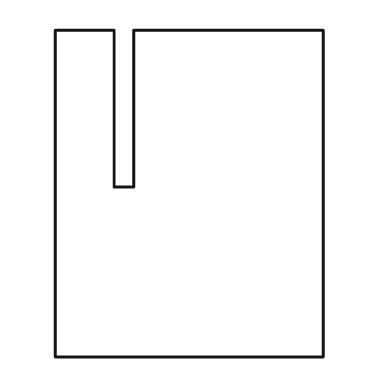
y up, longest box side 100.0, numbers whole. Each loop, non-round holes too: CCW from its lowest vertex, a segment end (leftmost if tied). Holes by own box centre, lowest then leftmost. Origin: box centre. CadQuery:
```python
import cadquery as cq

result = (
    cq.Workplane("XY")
    .moveTo(-41.0, -50.0)
    .lineTo(41.0, -50.0)
    .lineTo(41.0, 50.0)
    .lineTo(-17.0, 50.0)
    .lineTo(-17.0, 2.0)
    .lineTo(-23.0, 2.0)
    .lineTo(-23.0, 50.0)
    .lineTo(-41.0, 50.0)
    .close()
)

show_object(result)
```